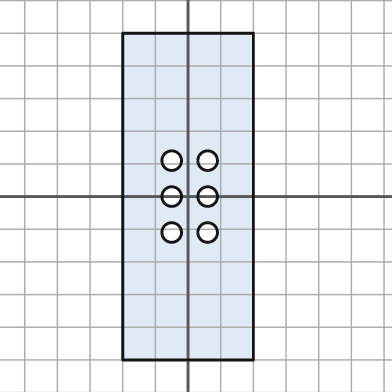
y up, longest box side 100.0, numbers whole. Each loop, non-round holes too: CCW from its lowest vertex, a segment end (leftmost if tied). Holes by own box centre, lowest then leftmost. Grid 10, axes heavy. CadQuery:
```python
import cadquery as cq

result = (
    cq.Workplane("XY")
    .moveTo(-20.0, -50.0)
    .lineTo(20.0, -50.0)
    .lineTo(20.0, 50.0)
    .lineTo(-20.0, 50.0)
    .close()
    .moveTo(-5.0, -11.0)
    .circle(3.0)
    .moveTo(6.0, -11.0)
    .circle(3.0)
    .moveTo(-5.0, 0.0)
    .circle(3.0)
    .moveTo(6.0, 0.0)
    .circle(3.0)
    .moveTo(-5.0, 11.0)
    .circle(3.0)
    .moveTo(6.0, 11.0)
    .circle(3.0)
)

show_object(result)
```